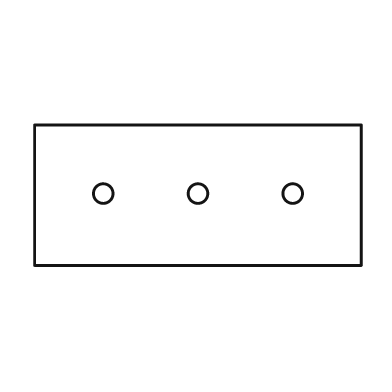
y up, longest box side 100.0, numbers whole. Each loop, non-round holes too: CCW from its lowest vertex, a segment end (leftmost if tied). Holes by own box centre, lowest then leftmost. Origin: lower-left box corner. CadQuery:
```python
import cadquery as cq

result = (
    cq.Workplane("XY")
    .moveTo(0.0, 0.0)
    .lineTo(100.0, 0.0)
    .lineTo(100.0, 43.0)
    .lineTo(0.0, 43.0)
    .close()
    .moveTo(21.0, 22.0)
    .circle(3.0)
    .moveTo(50.0, 22.0)
    .circle(3.0)
    .moveTo(79.0, 22.0)
    .circle(3.0)
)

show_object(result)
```